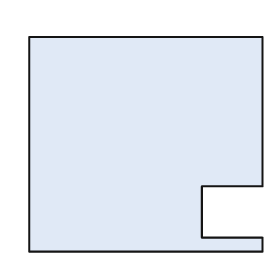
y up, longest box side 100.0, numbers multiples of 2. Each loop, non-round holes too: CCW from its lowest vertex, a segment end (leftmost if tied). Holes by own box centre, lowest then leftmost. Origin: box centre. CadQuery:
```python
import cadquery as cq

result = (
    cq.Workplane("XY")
    .moveTo(-50.0, -46.0)
    .lineTo(50.0, -46.0)
    .lineTo(50.0, -40.0)
    .lineTo(24.0, -40.0)
    .lineTo(24.0, -18.0)
    .lineTo(50.0, -18.0)
    .lineTo(50.0, 46.0)
    .lineTo(-50.0, 46.0)
    .close()
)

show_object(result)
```